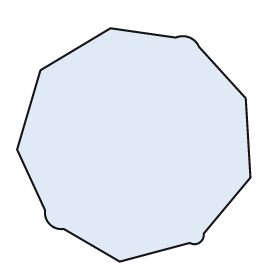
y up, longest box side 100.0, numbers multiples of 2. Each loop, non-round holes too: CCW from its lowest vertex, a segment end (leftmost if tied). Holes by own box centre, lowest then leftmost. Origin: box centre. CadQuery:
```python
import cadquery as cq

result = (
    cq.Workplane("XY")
    .moveTo(-6.0, -50.0)
    .lineTo(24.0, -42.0)
    .threePointArc((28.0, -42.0), (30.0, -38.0))
    .lineTo(50.0, -14.0)
    .lineTo(48.0, 20.0)
    .lineTo(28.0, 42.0)
    .threePointArc((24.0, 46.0), (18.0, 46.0))
    .lineTo(-10.0, 50.0)
    .lineTo(-40.0, 32.0)
    .lineTo(-50.0, -2.0)
    .lineTo(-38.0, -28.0)
    .threePointArc((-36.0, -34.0), (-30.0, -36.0))
    .close()
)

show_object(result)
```